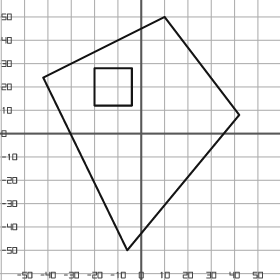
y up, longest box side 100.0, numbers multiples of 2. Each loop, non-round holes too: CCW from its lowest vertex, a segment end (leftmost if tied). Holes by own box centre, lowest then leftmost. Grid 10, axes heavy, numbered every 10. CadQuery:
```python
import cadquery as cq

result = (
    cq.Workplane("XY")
    .moveTo(-6.0, -50.0)
    .lineTo(42.0, 8.0)
    .lineTo(10.0, 50.0)
    .lineTo(-42.0, 24.0)
    .close()
    .moveTo(-20.0, 12.0)
    .lineTo(-4.0, 12.0)
    .lineTo(-4.0, 28.0)
    .lineTo(-20.0, 28.0)
    .close()
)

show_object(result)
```